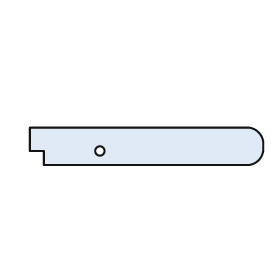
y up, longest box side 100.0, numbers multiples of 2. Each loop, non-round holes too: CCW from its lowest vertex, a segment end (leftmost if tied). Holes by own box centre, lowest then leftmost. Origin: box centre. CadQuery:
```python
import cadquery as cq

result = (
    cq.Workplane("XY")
    .moveTo(-44.0, -8.0)
    .lineTo(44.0, -8.0)
    .threePointArc((48.0, -6.0), (50.0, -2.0))
    .lineTo(50.0, 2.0)
    .threePointArc((48.0, 6.0), (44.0, 8.0))
    .lineTo(-50.0, 8.0)
    .lineTo(-50.0, -2.0)
    .lineTo(-44.0, -2.0)
    .close()
    .moveTo(-20.0, -2.0)
    .circle(2.0)
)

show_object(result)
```